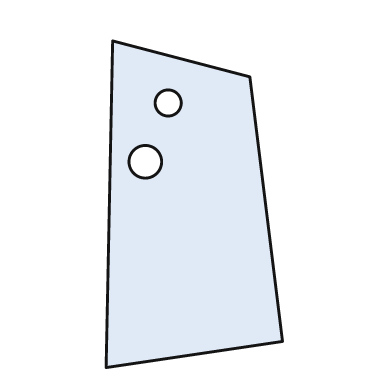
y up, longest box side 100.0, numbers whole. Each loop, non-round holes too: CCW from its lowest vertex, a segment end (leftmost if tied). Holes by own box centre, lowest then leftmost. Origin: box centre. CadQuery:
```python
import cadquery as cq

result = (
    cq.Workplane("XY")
    .moveTo(-27.0, -50.0)
    .lineTo(27.0, -42.0)
    .lineTo(17.0, 39.0)
    .lineTo(-25.0, 50.0)
    .close()
    .moveTo(-15.0, 13.0)
    .circle(5.0)
    .moveTo(-8.0, 31.0)
    .circle(4.0)
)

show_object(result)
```